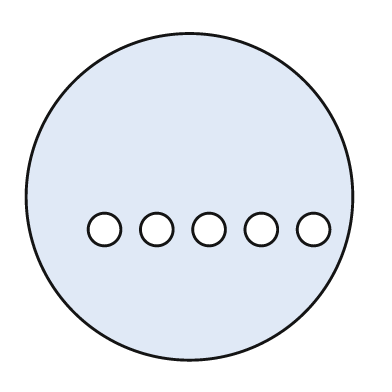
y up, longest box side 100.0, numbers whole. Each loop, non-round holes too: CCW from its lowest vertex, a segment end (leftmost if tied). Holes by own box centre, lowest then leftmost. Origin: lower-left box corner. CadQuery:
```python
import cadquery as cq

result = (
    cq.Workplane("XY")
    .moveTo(50.0, 50.0)
    .circle(50.0)
    .moveTo(24.0, 40.0)
    .circle(5.0)
    .moveTo(40.0, 40.0)
    .circle(5.0)
    .moveTo(56.0, 40.0)
    .circle(5.0)
    .moveTo(72.0, 40.0)
    .circle(5.0)
    .moveTo(88.0, 40.0)
    .circle(5.0)
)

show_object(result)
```